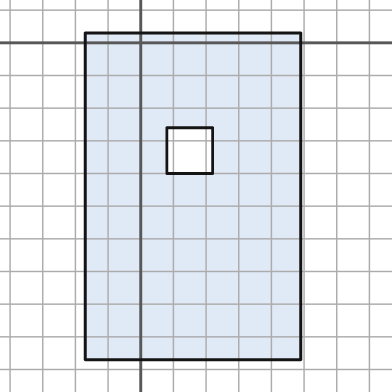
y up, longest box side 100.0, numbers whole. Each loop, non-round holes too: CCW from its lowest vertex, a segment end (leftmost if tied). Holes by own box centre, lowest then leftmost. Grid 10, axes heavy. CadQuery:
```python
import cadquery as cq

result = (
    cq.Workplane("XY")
    .moveTo(-17.0, -97.0)
    .lineTo(49.0, -97.0)
    .lineTo(49.0, 3.0)
    .lineTo(-17.0, 3.0)
    .close()
    .moveTo(8.0, -40.0)
    .lineTo(22.0, -40.0)
    .lineTo(22.0, -26.0)
    .lineTo(8.0, -26.0)
    .close()
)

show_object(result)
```